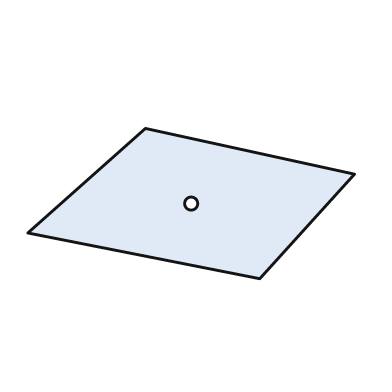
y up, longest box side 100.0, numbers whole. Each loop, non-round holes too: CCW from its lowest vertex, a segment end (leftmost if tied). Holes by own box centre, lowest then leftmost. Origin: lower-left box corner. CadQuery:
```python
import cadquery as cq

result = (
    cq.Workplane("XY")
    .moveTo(71.0, 0.0)
    .lineTo(100.0, 32.0)
    .lineTo(36.0, 46.0)
    .lineTo(0.0, 14.0)
    .close()
    .moveTo(50.0, 23.0)
    .circle(2.0)
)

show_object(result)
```